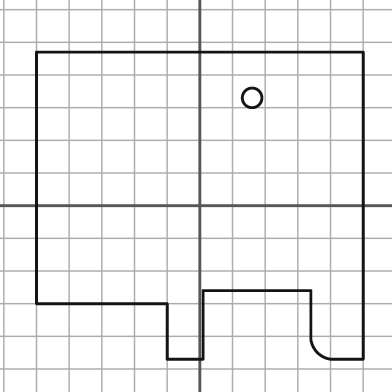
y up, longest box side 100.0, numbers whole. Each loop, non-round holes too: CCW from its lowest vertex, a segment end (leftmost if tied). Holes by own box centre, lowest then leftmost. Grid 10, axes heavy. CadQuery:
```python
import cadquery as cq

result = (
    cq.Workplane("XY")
    .moveTo(-10.0, -47.0)
    .lineTo(1.0, -47.0)
    .lineTo(1.0, -26.0)
    .lineTo(34.0, -26.0)
    .lineTo(34.0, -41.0)
    .threePointArc((36.0, -45.0), (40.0, -47.0))
    .lineTo(50.0, -47.0)
    .lineTo(50.0, 47.0)
    .lineTo(-50.0, 47.0)
    .lineTo(-50.0, -30.0)
    .lineTo(-10.0, -30.0)
    .close()
    .moveTo(16.0, 33.0)
    .circle(3.0)
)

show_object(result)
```